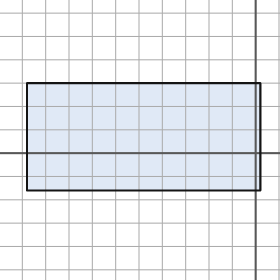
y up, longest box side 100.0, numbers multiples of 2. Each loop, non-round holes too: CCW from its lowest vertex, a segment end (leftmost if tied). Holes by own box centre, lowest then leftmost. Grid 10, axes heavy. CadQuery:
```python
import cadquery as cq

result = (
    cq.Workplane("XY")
    .moveTo(-98.0, -16.0)
    .lineTo(2.0, -16.0)
    .lineTo(2.0, 30.0)
    .lineTo(-98.0, 30.0)
    .close()
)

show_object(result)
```